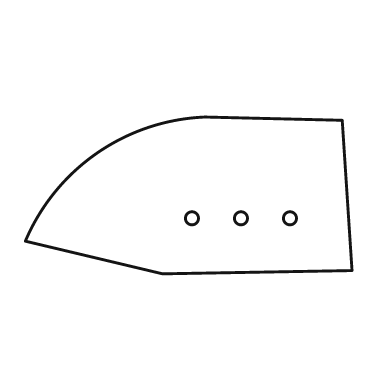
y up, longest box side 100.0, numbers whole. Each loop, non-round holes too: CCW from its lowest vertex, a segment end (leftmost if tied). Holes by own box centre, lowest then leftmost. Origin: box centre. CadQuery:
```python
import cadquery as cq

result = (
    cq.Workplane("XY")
    .moveTo(-8.0, -24.0)
    .lineTo(50.0, -23.0)
    .lineTo(47.0, 23.0)
    .lineTo(5.0, 24.0)
    .threePointArc((-28.0, 13.0), (-50.0, -14.0))
    .close()
    .moveTo(1.0, -7.0)
    .circle(2.0)
    .moveTo(16.0, -7.0)
    .circle(2.0)
    .moveTo(31.0, -7.0)
    .circle(2.0)
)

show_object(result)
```